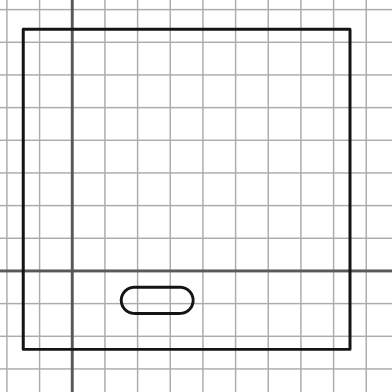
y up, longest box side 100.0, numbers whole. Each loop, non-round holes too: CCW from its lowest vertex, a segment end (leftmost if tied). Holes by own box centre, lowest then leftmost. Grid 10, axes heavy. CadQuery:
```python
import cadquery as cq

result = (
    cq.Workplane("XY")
    .moveTo(-15.0, -24.0)
    .lineTo(85.0, -24.0)
    .lineTo(85.0, 74.0)
    .lineTo(-15.0, 74.0)
    .close()
    .moveTo(19.0, -13.0)
    .lineTo(33.0, -13.0)
    .threePointArc((37.0, -9.0), (33.0, -5.0))
    .lineTo(19.0, -5.0)
    .threePointArc((15.0, -9.0), (19.0, -13.0))
    .close()
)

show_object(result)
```